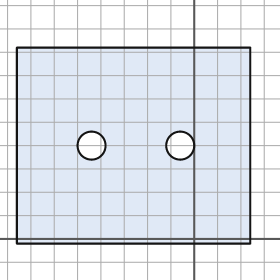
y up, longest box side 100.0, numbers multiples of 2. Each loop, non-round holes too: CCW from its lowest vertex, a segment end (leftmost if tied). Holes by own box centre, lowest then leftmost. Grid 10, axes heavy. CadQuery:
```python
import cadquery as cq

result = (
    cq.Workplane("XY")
    .moveTo(-76.0, -2.0)
    .lineTo(24.0, -2.0)
    .lineTo(24.0, 82.0)
    .lineTo(-76.0, 82.0)
    .close()
    .moveTo(-44.0, 40.0)
    .circle(6.0)
    .moveTo(-6.0, 40.0)
    .circle(6.0)
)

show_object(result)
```